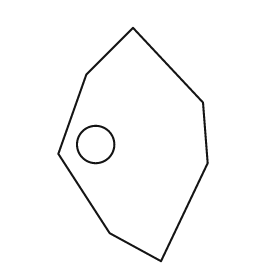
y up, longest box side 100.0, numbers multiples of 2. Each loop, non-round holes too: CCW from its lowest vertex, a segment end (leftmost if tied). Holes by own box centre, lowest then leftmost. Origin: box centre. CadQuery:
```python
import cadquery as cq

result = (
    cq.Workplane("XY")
    .moveTo(12.0, -50.0)
    .lineTo(32.0, -8.0)
    .lineTo(30.0, 18.0)
    .lineTo(0.0, 50.0)
    .lineTo(-20.0, 30.0)
    .lineTo(-32.0, -4.0)
    .lineTo(-10.0, -38.0)
    .close()
    .moveTo(-16.0, 0.0)
    .circle(8.0)
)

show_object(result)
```